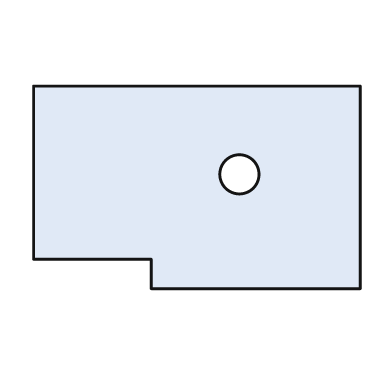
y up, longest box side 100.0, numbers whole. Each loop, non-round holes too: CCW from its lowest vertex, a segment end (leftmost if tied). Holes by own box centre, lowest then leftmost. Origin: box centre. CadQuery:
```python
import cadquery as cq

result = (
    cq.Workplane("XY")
    .moveTo(-14.0, -31.0)
    .lineTo(50.0, -31.0)
    .lineTo(50.0, 31.0)
    .lineTo(-50.0, 31.0)
    .lineTo(-50.0, -22.0)
    .lineTo(-14.0, -22.0)
    .close()
    .moveTo(13.0, 4.0)
    .circle(6.0)
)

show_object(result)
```